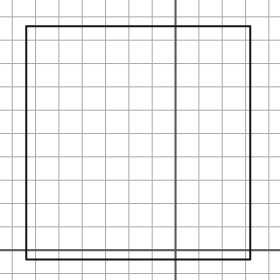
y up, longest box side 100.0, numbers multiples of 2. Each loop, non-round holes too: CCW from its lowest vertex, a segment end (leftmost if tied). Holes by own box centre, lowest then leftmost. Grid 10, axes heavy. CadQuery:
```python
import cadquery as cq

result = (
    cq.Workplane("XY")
    .moveTo(-64.0, -4.0)
    .lineTo(32.0, -4.0)
    .lineTo(32.0, 96.0)
    .lineTo(-64.0, 96.0)
    .close()
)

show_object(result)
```